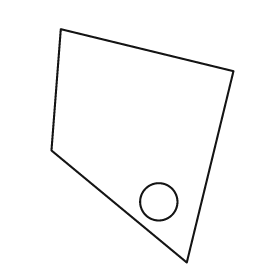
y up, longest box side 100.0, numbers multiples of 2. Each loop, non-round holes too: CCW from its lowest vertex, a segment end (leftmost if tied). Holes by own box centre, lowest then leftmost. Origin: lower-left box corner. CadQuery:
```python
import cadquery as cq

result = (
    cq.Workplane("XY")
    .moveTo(58.0, 0.0)
    .lineTo(78.0, 82.0)
    .lineTo(4.0, 100.0)
    .lineTo(0.0, 48.0)
    .close()
    .moveTo(46.0, 26.0)
    .circle(8.0)
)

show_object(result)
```